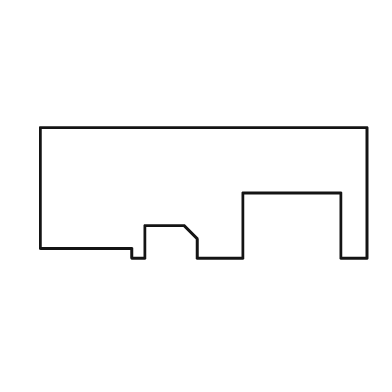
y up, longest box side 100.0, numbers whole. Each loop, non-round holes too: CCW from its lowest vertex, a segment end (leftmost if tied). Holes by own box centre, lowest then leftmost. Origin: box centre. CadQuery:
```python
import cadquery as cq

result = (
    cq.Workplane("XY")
    .moveTo(-22.0, -20.0)
    .lineTo(-18.0, -20.0)
    .lineTo(-18.0, -10.0)
    .lineTo(-6.0, -10.0)
    .lineTo(-2.0, -14.0)
    .lineTo(-2.0, -20.0)
    .lineTo(12.0, -20.0)
    .lineTo(12.0, 0.0)
    .lineTo(42.0, 0.0)
    .lineTo(42.0, -20.0)
    .lineTo(50.0, -20.0)
    .lineTo(50.0, 20.0)
    .lineTo(-50.0, 20.0)
    .lineTo(-50.0, -17.0)
    .lineTo(-22.0, -17.0)
    .close()
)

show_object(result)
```